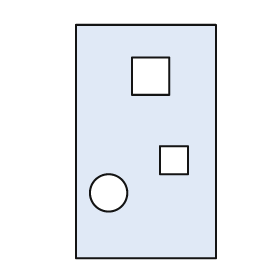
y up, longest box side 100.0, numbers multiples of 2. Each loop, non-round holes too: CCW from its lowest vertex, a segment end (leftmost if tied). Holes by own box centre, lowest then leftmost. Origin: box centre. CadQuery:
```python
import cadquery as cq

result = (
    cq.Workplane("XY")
    .moveTo(-30.0, -50.0)
    .lineTo(30.0, -50.0)
    .lineTo(30.0, 50.0)
    .lineTo(-30.0, 50.0)
    .close()
    .moveTo(-16.0, -22.0)
    .circle(8.0)
    .moveTo(6.0, -14.0)
    .lineTo(18.0, -14.0)
    .lineTo(18.0, -2.0)
    .lineTo(6.0, -2.0)
    .close()
    .moveTo(-6.0, 20.0)
    .lineTo(10.0, 20.0)
    .lineTo(10.0, 36.0)
    .lineTo(-6.0, 36.0)
    .close()
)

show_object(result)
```